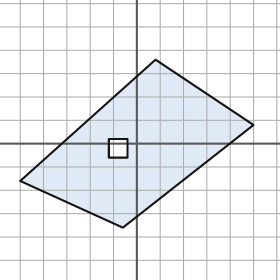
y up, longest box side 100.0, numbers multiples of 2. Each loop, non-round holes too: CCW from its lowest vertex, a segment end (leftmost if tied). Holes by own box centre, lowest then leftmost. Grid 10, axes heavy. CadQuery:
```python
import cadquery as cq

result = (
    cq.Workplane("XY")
    .moveTo(-6.0, -36.0)
    .lineTo(50.0, 8.0)
    .lineTo(8.0, 36.0)
    .lineTo(-50.0, -16.0)
    .close()
    .moveTo(-12.0, -6.0)
    .lineTo(-4.0, -6.0)
    .lineTo(-4.0, 2.0)
    .lineTo(-12.0, 2.0)
    .close()
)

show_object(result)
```